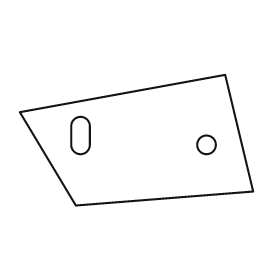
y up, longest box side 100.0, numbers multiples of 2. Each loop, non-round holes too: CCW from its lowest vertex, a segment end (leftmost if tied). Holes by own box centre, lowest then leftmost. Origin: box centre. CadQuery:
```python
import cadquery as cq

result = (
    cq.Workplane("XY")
    .moveTo(-26.0, -28.0)
    .lineTo(50.0, -22.0)
    .lineTo(38.0, 28.0)
    .lineTo(-50.0, 12.0)
    .close()
    .moveTo(30.0, -2.0)
    .circle(4.0)
    .moveTo(-28.0, -2.0)
    .threePointArc((-24.0, -6.0), (-20.0, -2.0))
    .lineTo(-20.0, 6.0)
    .threePointArc((-24.0, 10.0), (-28.0, 6.0))
    .close()
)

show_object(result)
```